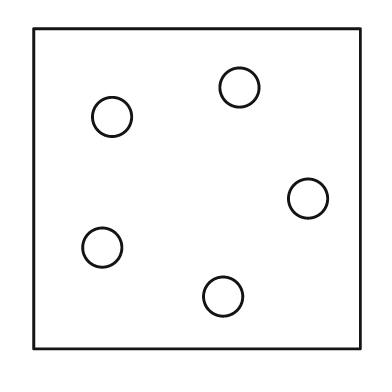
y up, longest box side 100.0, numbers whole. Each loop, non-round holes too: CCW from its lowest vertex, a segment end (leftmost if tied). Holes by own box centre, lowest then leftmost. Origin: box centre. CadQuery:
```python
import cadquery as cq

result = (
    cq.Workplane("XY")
    .moveTo(-50.0, -49.0)
    .lineTo(50.0, -49.0)
    .lineTo(50.0, 49.0)
    .lineTo(-50.0, 49.0)
    .close()
    .moveTo(8.0, -33.0)
    .circle(6.0)
    .moveTo(-29.0, -18.0)
    .circle(6.0)
    .moveTo(34.0, -3.0)
    .circle(6.0)
    .moveTo(-26.0, 22.0)
    .circle(6.0)
    .moveTo(13.0, 31.0)
    .circle(6.0)
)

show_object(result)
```